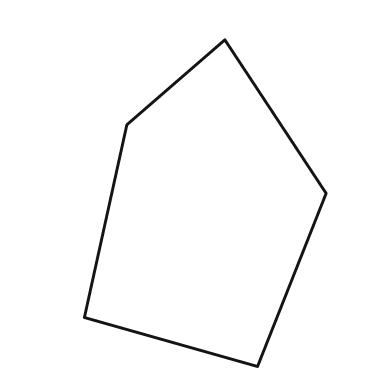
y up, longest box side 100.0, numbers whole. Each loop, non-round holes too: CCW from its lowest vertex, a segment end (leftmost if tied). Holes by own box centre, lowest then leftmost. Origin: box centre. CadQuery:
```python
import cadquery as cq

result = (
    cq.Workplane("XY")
    .moveTo(16.0, -50.0)
    .lineTo(37.0, 3.0)
    .lineTo(6.0, 50.0)
    .lineTo(-24.0, 24.0)
    .lineTo(-37.0, -35.0)
    .close()
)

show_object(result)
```